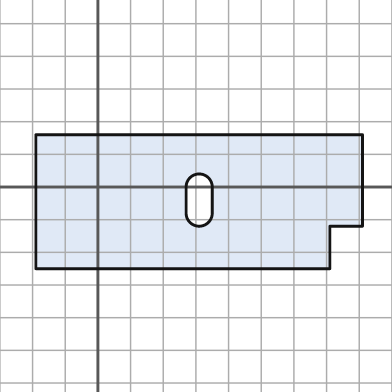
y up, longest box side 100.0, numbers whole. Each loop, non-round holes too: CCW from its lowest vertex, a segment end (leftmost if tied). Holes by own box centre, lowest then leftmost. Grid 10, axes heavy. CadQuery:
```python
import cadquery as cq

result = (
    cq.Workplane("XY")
    .moveTo(-19.0, -25.0)
    .lineTo(71.0, -25.0)
    .lineTo(71.0, -12.0)
    .lineTo(81.0, -12.0)
    .lineTo(81.0, 16.0)
    .lineTo(-19.0, 16.0)
    .close()
    .moveTo(27.0, -8.0)
    .threePointArc((31.0, -12.0), (35.0, -8.0))
    .lineTo(35.0, 0.0)
    .threePointArc((31.0, 4.0), (27.0, 0.0))
    .close()
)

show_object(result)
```